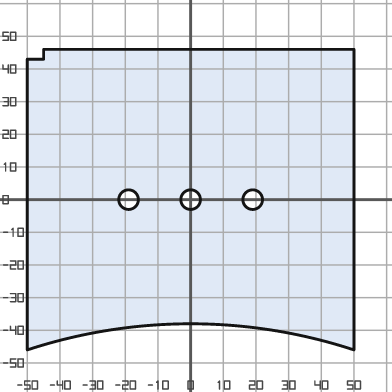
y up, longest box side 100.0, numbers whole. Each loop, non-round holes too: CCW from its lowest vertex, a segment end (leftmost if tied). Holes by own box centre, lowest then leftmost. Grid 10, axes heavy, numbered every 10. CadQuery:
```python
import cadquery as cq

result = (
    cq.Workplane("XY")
    .moveTo(-50.0, -46.0)
    .threePointArc((0.0, -38.0), (50.0, -46.0))
    .lineTo(50.0, 46.0)
    .lineTo(-45.0, 46.0)
    .lineTo(-45.0, 43.0)
    .lineTo(-50.0, 43.0)
    .close()
    .moveTo(-19.0, 0.0)
    .circle(3.0)
    .moveTo(0.0, 0.0)
    .circle(3.0)
    .moveTo(19.0, 0.0)
    .circle(3.0)
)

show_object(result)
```